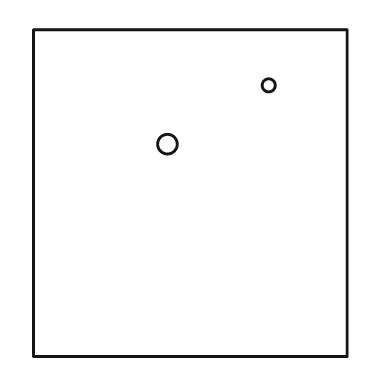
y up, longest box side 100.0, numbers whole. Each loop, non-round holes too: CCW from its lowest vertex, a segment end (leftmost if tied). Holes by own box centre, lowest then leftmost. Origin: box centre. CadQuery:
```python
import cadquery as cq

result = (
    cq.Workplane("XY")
    .moveTo(-48.0, -50.0)
    .lineTo(48.0, -50.0)
    .lineTo(48.0, 50.0)
    .lineTo(-48.0, 50.0)
    .close()
    .moveTo(-7.0, 15.0)
    .circle(3.0)
    .moveTo(24.0, 33.0)
    .circle(2.0)
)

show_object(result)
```